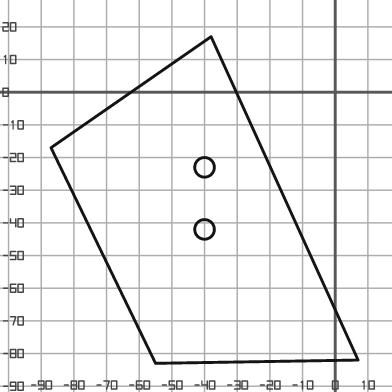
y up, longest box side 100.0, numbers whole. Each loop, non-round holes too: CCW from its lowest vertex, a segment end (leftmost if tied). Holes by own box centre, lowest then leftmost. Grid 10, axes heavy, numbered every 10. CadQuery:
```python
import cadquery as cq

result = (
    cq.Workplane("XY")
    .moveTo(-55.0, -83.0)
    .lineTo(7.0, -82.0)
    .lineTo(-38.0, 17.0)
    .lineTo(-87.0, -17.0)
    .close()
    .moveTo(-40.0, -42.0)
    .circle(3.0)
    .moveTo(-40.0, -23.0)
    .circle(3.0)
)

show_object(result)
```